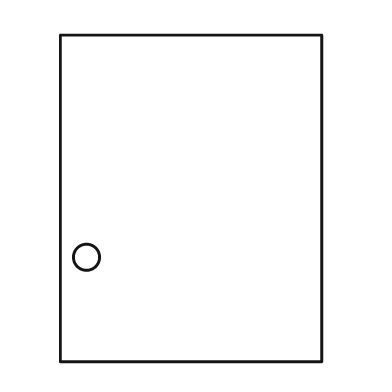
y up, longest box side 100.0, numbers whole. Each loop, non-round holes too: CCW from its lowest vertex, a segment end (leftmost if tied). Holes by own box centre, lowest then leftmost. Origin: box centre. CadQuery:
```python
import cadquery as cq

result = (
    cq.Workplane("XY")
    .moveTo(-40.0, -50.0)
    .lineTo(40.0, -50.0)
    .lineTo(40.0, 50.0)
    .lineTo(-40.0, 50.0)
    .close()
    .moveTo(-32.0, -18.0)
    .circle(4.0)
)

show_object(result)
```